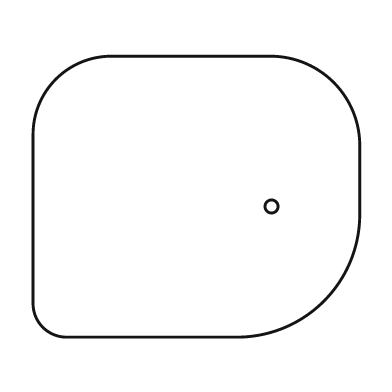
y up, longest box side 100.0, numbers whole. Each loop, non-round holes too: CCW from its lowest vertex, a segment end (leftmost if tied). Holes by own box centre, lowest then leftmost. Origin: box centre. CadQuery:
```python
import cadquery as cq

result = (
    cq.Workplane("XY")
    .moveTo(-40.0, -43.0)
    .lineTo(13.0, -43.0)
    .threePointArc((39.0, -32.0), (50.0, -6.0))
    .lineTo(50.0, 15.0)
    .threePointArc((42.0, 35.0), (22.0, 43.0))
    .lineTo(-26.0, 43.0)
    .threePointArc((-43.0, 36.0), (-50.0, 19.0))
    .lineTo(-50.0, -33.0)
    .threePointArc((-47.0, -40.0), (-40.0, -43.0))
    .close()
    .moveTo(23.0, -3.0)
    .circle(2.0)
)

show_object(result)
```